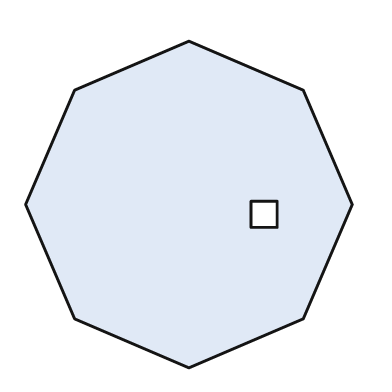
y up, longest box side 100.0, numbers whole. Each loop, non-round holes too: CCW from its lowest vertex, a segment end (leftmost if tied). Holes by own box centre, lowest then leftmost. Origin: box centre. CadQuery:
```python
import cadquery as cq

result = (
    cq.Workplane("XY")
    .moveTo(0.0, -50.0)
    .lineTo(35.0, -35.0)
    .lineTo(50.0, 0.0)
    .lineTo(35.0, 35.0)
    .lineTo(0.0, 50.0)
    .lineTo(-35.0, 35.0)
    .lineTo(-50.0, 0.0)
    .lineTo(-35.0, -35.0)
    .close()
    .moveTo(19.0, -7.0)
    .lineTo(27.0, -7.0)
    .lineTo(27.0, 1.0)
    .lineTo(19.0, 1.0)
    .close()
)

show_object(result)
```